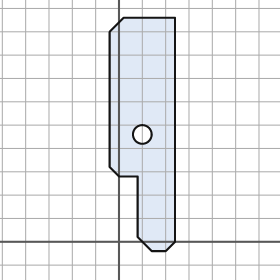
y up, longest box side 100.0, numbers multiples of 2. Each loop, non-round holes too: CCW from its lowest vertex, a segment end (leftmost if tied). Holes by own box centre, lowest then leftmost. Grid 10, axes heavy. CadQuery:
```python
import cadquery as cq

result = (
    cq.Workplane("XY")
    .moveTo(14.0, -4.0)
    .lineTo(20.0, -4.0)
    .lineTo(24.0, 0.0)
    .lineTo(24.0, 96.0)
    .lineTo(2.0, 96.0)
    .lineTo(-4.0, 90.0)
    .lineTo(-4.0, 32.0)
    .lineTo(0.0, 28.0)
    .lineTo(8.0, 28.0)
    .lineTo(8.0, 2.0)
    .close()
    .moveTo(10.0, 46.0)
    .circle(4.0)
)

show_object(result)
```